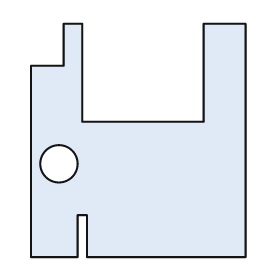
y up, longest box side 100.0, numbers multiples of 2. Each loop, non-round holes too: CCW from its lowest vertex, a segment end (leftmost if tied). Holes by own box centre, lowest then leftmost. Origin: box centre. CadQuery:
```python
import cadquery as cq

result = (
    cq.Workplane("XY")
    .moveTo(-46.0, -50.0)
    .lineTo(-26.0, -50.0)
    .lineTo(-26.0, -32.0)
    .lineTo(-22.0, -32.0)
    .lineTo(-22.0, -50.0)
    .lineTo(46.0, -50.0)
    .lineTo(46.0, 50.0)
    .lineTo(28.0, 50.0)
    .lineTo(28.0, 8.0)
    .lineTo(-24.0, 8.0)
    .lineTo(-24.0, 50.0)
    .lineTo(-32.0, 50.0)
    .lineTo(-32.0, 32.0)
    .lineTo(-46.0, 32.0)
    .close()
    .moveTo(-34.0, -10.0)
    .circle(8.0)
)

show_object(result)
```